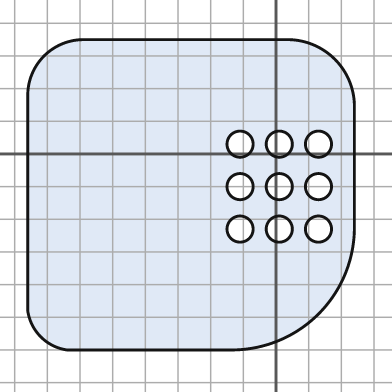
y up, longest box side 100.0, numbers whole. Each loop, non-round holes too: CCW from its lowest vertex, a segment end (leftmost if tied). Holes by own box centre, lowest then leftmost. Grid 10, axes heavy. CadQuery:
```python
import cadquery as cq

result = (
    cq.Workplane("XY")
    .moveTo(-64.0, -60.0)
    .lineTo(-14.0, -60.0)
    .threePointArc((13.0, -49.0), (24.0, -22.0))
    .lineTo(24.0, 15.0)
    .threePointArc((18.0, 29.0), (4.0, 35.0))
    .lineTo(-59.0, 35.0)
    .threePointArc((-71.0, 30.0), (-76.0, 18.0))
    .lineTo(-76.0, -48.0)
    .threePointArc((-72.0, -56.0), (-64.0, -60.0))
    .close()
    .moveTo(-11.0, -23.0)
    .circle(4.0)
    .moveTo(1.0, -23.0)
    .circle(4.0)
    .moveTo(13.0, -23.0)
    .circle(4.0)
    .moveTo(-11.0, -10.0)
    .circle(4.0)
    .moveTo(1.0, -10.0)
    .circle(4.0)
    .moveTo(13.0, -10.0)
    .circle(4.0)
    .moveTo(-11.0, 3.0)
    .circle(4.0)
    .moveTo(1.0, 3.0)
    .circle(4.0)
    .moveTo(13.0, 3.0)
    .circle(4.0)
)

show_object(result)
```